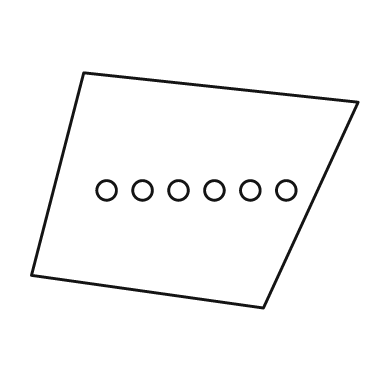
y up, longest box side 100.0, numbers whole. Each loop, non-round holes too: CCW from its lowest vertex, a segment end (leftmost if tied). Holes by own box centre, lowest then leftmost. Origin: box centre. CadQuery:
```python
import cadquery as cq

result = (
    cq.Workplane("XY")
    .moveTo(21.0, -36.0)
    .lineTo(50.0, 27.0)
    .lineTo(-34.0, 36.0)
    .lineTo(-50.0, -26.0)
    .close()
    .moveTo(-27.0, 0.0)
    .circle(3.0)
    .moveTo(-16.0, 0.0)
    .circle(3.0)
    .moveTo(-5.0, 0.0)
    .circle(3.0)
    .moveTo(6.0, 0.0)
    .circle(3.0)
    .moveTo(17.0, 0.0)
    .circle(3.0)
    .moveTo(28.0, 0.0)
    .circle(3.0)
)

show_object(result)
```